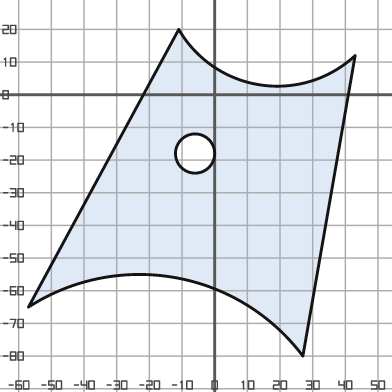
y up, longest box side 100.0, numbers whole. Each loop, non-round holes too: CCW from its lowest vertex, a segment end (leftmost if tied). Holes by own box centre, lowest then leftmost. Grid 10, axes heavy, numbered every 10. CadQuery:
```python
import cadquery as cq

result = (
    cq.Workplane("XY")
    .moveTo(27.0, -80.0)
    .lineTo(43.0, 12.0)
    .threePointArc((14.0, 3.0), (-11.0, 20.0))
    .lineTo(-57.0, -65.0)
    .threePointArc((-12.0, -56.0), (27.0, -80.0))
    .close()
    .moveTo(-6.0, -18.0)
    .circle(6.0)
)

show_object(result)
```